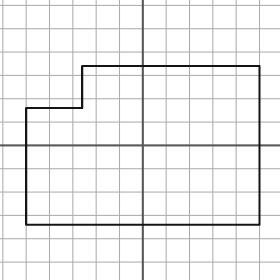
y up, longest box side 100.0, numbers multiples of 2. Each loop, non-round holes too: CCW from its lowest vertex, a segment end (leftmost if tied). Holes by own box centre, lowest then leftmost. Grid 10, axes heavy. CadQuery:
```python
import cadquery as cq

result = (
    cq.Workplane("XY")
    .moveTo(-50.0, -34.0)
    .lineTo(50.0, -34.0)
    .lineTo(50.0, 34.0)
    .lineTo(-26.0, 34.0)
    .lineTo(-26.0, 16.0)
    .lineTo(-50.0, 16.0)
    .close()
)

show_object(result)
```